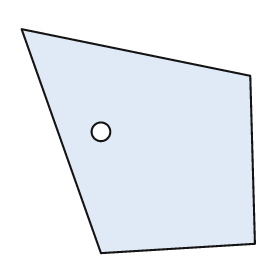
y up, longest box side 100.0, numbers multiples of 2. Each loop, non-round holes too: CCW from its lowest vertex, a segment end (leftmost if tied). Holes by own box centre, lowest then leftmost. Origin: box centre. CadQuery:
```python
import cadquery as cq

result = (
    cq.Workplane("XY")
    .moveTo(-16.0, -48.0)
    .lineTo(50.0, -44.0)
    .lineTo(48.0, 28.0)
    .lineTo(-50.0, 48.0)
    .close()
    .moveTo(-16.0, 4.0)
    .circle(4.0)
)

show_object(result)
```